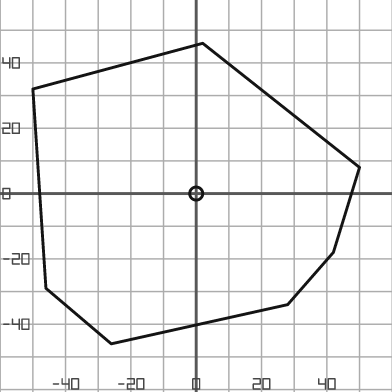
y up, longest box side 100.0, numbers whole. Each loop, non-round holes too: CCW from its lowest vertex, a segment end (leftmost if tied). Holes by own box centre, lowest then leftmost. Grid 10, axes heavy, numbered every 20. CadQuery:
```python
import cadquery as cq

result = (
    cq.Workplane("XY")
    .moveTo(-26.0, -46.0)
    .lineTo(28.0, -34.0)
    .lineTo(42.0, -18.0)
    .lineTo(50.0, 8.0)
    .lineTo(2.0, 46.0)
    .lineTo(-50.0, 32.0)
    .lineTo(-46.0, -29.0)
    .close()
    .moveTo(0.0, 0.0)
    .circle(2.0)
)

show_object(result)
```